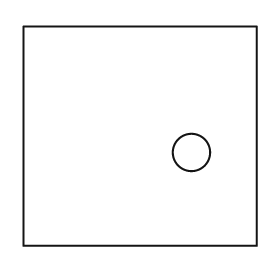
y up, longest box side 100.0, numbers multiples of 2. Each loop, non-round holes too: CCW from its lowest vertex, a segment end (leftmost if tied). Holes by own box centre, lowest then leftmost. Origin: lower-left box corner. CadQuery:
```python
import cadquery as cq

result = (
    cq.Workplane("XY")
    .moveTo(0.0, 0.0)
    .lineTo(100.0, 0.0)
    .lineTo(100.0, 94.0)
    .lineTo(0.0, 94.0)
    .close()
    .moveTo(72.0, 40.0)
    .circle(8.0)
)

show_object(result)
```